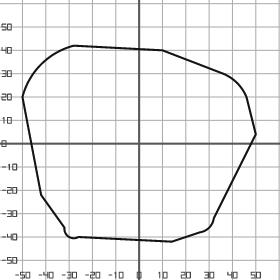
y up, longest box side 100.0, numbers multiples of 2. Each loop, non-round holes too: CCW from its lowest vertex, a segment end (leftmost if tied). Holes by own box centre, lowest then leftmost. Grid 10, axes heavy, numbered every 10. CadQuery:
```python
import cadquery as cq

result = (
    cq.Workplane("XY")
    .moveTo(14.0, -42.0)
    .lineTo(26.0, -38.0)
    .threePointArc((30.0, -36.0), (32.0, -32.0))
    .lineTo(50.0, 4.0)
    .lineTo(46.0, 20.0)
    .threePointArc((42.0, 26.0), (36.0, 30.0))
    .lineTo(10.0, 40.0)
    .lineTo(-28.0, 42.0)
    .threePointArc((-42.0, 34.0), (-50.0, 20.0))
    .lineTo(-42.0, -22.0)
    .lineTo(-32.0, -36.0)
    .threePointArc((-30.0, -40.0), (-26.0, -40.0))
    .close()
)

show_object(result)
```